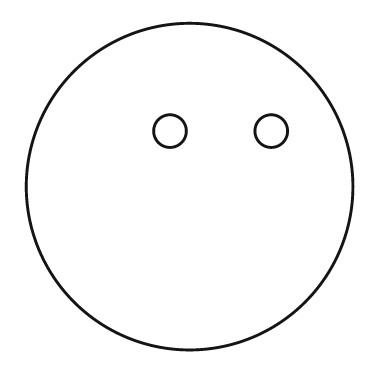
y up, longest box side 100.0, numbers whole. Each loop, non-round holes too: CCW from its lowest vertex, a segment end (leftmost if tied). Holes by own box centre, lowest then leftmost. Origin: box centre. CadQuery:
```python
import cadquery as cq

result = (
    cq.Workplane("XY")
    .moveTo(0.0, 0.0)
    .circle(50.0)
    .moveTo(-6.0, 17.0)
    .circle(5.0)
    .moveTo(25.0, 17.0)
    .circle(5.0)
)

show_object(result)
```